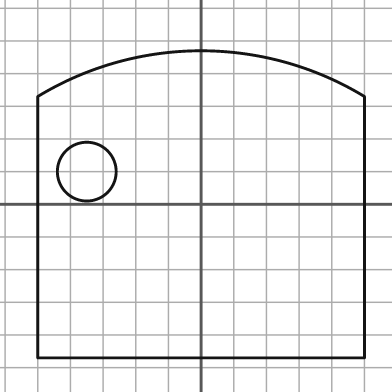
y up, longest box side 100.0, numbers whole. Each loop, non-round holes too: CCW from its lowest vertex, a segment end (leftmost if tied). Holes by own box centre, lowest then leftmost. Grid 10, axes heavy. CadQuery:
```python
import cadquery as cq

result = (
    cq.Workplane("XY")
    .moveTo(-50.0, -47.0)
    .lineTo(50.0, -47.0)
    .lineTo(50.0, 33.0)
    .threePointArc((0.0, 47.0), (-50.0, 33.0))
    .close()
    .moveTo(-35.0, 10.0)
    .circle(9.0)
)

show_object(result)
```